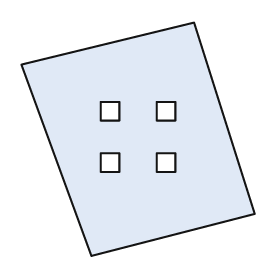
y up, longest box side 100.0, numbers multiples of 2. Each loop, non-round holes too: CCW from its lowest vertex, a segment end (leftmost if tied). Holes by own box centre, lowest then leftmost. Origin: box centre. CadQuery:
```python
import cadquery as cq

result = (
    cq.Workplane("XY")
    .moveTo(-20.0, -50.0)
    .lineTo(50.0, -32.0)
    .lineTo(24.0, 50.0)
    .lineTo(-50.0, 32.0)
    .close()
    .moveTo(-16.0, -14.0)
    .lineTo(-8.0, -14.0)
    .lineTo(-8.0, -6.0)
    .lineTo(-16.0, -6.0)
    .close()
    .moveTo(8.0, -14.0)
    .lineTo(16.0, -14.0)
    .lineTo(16.0, -6.0)
    .lineTo(8.0, -6.0)
    .close()
    .moveTo(-16.0, 8.0)
    .lineTo(-8.0, 8.0)
    .lineTo(-8.0, 16.0)
    .lineTo(-16.0, 16.0)
    .close()
    .moveTo(8.0, 8.0)
    .lineTo(16.0, 8.0)
    .lineTo(16.0, 16.0)
    .lineTo(8.0, 16.0)
    .close()
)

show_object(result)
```